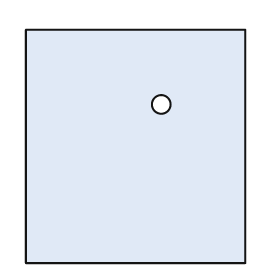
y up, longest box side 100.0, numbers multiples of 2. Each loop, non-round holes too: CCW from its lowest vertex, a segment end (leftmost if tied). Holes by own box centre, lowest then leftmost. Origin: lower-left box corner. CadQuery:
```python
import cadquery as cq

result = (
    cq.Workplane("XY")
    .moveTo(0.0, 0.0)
    .lineTo(94.0, 0.0)
    .lineTo(94.0, 100.0)
    .lineTo(0.0, 100.0)
    .close()
    .moveTo(58.0, 68.0)
    .circle(4.0)
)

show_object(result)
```